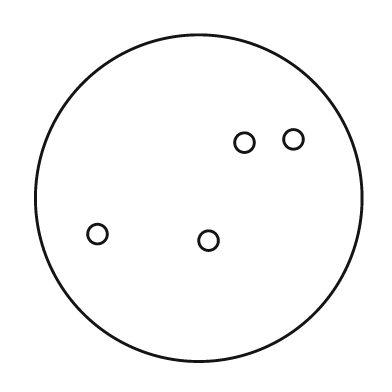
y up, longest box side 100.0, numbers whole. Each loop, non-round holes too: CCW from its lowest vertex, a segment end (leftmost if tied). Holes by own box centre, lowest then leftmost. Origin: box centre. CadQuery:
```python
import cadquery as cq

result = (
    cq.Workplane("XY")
    .moveTo(0.0, 0.0)
    .circle(50.0)
    .moveTo(3.0, -13.0)
    .circle(3.0)
    .moveTo(-31.0, -11.0)
    .circle(3.0)
    .moveTo(14.0, 17.0)
    .circle(3.0)
    .moveTo(29.0, 18.0)
    .circle(3.0)
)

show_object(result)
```